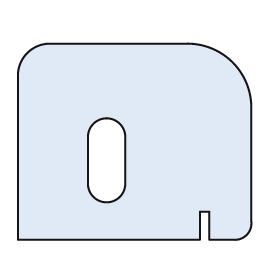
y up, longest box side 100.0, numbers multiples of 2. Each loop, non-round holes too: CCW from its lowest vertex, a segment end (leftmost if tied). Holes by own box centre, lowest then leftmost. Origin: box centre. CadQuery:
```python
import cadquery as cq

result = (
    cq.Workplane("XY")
    .moveTo(-50.0, -42.0)
    .lineTo(28.0, -42.0)
    .lineTo(28.0, -30.0)
    .lineTo(32.0, -30.0)
    .lineTo(32.0, -42.0)
    .lineTo(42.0, -42.0)
    .threePointArc((48.0, -40.0), (50.0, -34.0))
    .lineTo(50.0, 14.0)
    .threePointArc((42.0, 34.0), (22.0, 42.0))
    .lineTo(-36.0, 42.0)
    .threePointArc((-46.0, 38.0), (-50.0, 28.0))
    .close()
    .moveTo(-20.0, -18.0)
    .threePointArc((-12.0, -26.0), (-4.0, -18.0))
    .lineTo(-4.0, 2.0)
    .threePointArc((-12.0, 10.0), (-20.0, 2.0))
    .close()
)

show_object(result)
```